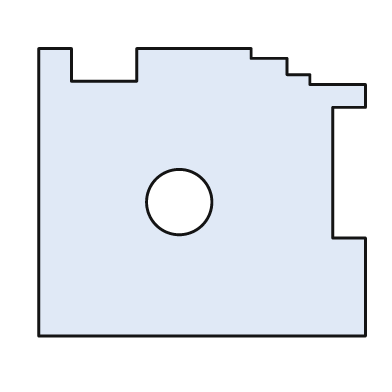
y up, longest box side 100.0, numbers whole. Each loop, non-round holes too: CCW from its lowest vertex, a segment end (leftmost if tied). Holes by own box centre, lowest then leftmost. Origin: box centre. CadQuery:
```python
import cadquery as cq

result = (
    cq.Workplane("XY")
    .moveTo(-50.0, -44.0)
    .lineTo(50.0, -44.0)
    .lineTo(50.0, -14.0)
    .lineTo(40.0, -14.0)
    .lineTo(40.0, 26.0)
    .lineTo(50.0, 26.0)
    .lineTo(50.0, 33.0)
    .lineTo(33.0, 33.0)
    .lineTo(33.0, 36.0)
    .lineTo(26.0, 36.0)
    .lineTo(26.0, 41.0)
    .lineTo(15.0, 41.0)
    .lineTo(15.0, 44.0)
    .lineTo(-20.0, 44.0)
    .lineTo(-20.0, 34.0)
    .lineTo(-40.0, 34.0)
    .lineTo(-40.0, 44.0)
    .lineTo(-50.0, 44.0)
    .close()
    .moveTo(-7.0, -3.0)
    .circle(10.0)
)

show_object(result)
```